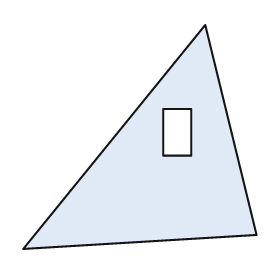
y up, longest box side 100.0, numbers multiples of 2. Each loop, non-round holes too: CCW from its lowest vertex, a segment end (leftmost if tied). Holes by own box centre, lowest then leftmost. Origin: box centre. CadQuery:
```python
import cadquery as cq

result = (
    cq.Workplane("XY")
    .moveTo(-50.0, -48.0)
    .lineTo(50.0, -42.0)
    .lineTo(28.0, 48.0)
    .close()
    .moveTo(10.0, -8.0)
    .lineTo(22.0, -8.0)
    .lineTo(22.0, 12.0)
    .lineTo(10.0, 12.0)
    .close()
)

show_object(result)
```